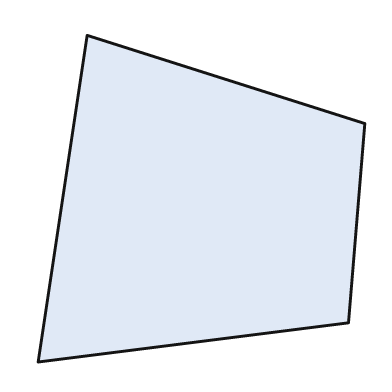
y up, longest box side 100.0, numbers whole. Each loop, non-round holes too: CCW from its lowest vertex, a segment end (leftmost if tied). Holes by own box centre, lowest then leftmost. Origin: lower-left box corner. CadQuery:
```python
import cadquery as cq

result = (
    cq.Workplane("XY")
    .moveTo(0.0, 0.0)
    .lineTo(95.0, 12.0)
    .lineTo(100.0, 73.0)
    .lineTo(15.0, 100.0)
    .close()
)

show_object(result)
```